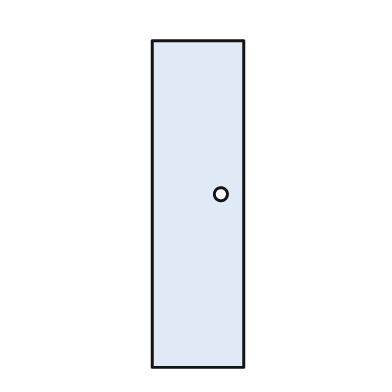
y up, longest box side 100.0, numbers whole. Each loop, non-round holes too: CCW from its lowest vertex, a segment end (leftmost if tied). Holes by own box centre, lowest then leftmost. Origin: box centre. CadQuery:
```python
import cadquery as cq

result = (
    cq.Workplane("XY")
    .moveTo(-14.0, -50.0)
    .lineTo(14.0, -50.0)
    .lineTo(14.0, 50.0)
    .lineTo(-14.0, 50.0)
    .close()
    .moveTo(7.0, 3.0)
    .circle(2.0)
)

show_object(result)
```